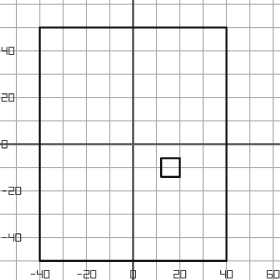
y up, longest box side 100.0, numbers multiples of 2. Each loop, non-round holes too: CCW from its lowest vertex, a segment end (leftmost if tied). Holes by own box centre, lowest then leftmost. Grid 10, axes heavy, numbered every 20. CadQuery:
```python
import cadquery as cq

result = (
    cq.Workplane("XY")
    .moveTo(-40.0, -50.0)
    .lineTo(40.0, -50.0)
    .lineTo(40.0, 50.0)
    .lineTo(-40.0, 50.0)
    .close()
    .moveTo(12.0, -14.0)
    .lineTo(20.0, -14.0)
    .lineTo(20.0, -6.0)
    .lineTo(12.0, -6.0)
    .close()
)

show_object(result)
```